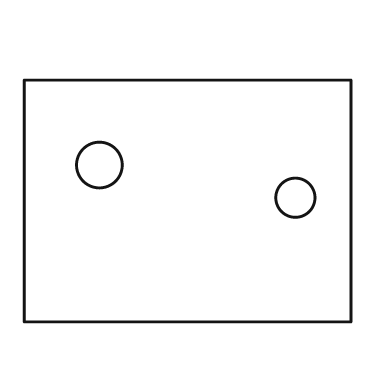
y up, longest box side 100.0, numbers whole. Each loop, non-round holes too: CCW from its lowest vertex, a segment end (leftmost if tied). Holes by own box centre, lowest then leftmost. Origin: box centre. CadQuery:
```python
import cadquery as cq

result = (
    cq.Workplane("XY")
    .moveTo(-50.0, -37.0)
    .lineTo(50.0, -37.0)
    .lineTo(50.0, 37.0)
    .lineTo(-50.0, 37.0)
    .close()
    .moveTo(33.0, 1.0)
    .circle(6.0)
    .moveTo(-27.0, 11.0)
    .circle(7.0)
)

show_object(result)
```